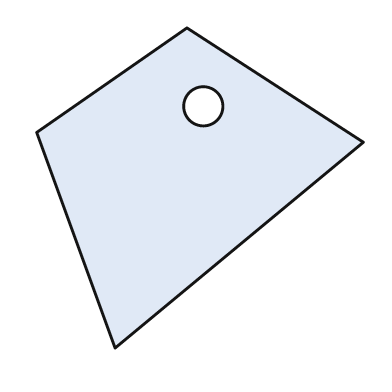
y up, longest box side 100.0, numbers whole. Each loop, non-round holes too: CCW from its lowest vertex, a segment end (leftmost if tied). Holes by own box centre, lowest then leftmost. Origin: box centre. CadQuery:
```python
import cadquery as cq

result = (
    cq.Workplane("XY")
    .moveTo(-26.0, -49.0)
    .lineTo(50.0, 14.0)
    .lineTo(-4.0, 49.0)
    .lineTo(-50.0, 17.0)
    .close()
    .moveTo(1.0, 25.0)
    .circle(6.0)
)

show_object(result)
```